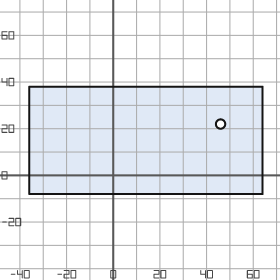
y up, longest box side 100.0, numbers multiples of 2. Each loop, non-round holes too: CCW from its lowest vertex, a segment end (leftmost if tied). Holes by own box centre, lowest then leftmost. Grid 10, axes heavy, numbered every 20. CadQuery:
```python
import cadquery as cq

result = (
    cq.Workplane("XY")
    .moveTo(-36.0, -8.0)
    .lineTo(64.0, -8.0)
    .lineTo(64.0, 38.0)
    .lineTo(-36.0, 38.0)
    .close()
    .moveTo(46.0, 22.0)
    .circle(2.0)
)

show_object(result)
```